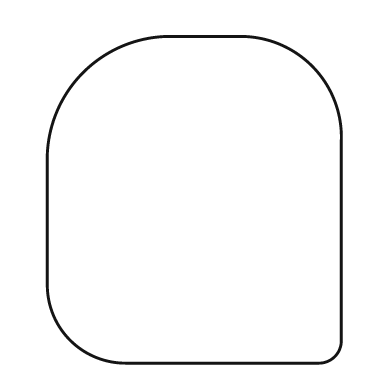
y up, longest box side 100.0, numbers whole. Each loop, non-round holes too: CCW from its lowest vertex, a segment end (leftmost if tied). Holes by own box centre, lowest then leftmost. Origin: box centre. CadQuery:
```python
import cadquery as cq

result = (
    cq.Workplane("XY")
    .moveTo(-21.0, -50.0)
    .lineTo(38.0, -50.0)
    .threePointArc((43.0, -48.0), (45.0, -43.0))
    .lineTo(45.0, 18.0)
    .threePointArc((36.0, 41.0), (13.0, 50.0))
    .lineTo(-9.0, 50.0)
    .threePointArc((-34.0, 39.0), (-45.0, 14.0))
    .lineTo(-45.0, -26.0)
    .threePointArc((-38.0, -43.0), (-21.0, -50.0))
    .close()
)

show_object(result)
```